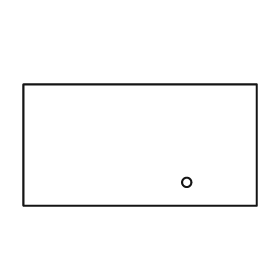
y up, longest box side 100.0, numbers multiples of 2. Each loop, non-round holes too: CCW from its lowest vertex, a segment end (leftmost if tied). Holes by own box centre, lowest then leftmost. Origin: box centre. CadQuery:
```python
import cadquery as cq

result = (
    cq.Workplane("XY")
    .moveTo(-50.0, -26.0)
    .lineTo(50.0, -26.0)
    .lineTo(50.0, 26.0)
    .lineTo(-50.0, 26.0)
    .close()
    .moveTo(20.0, -16.0)
    .circle(2.0)
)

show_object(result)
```